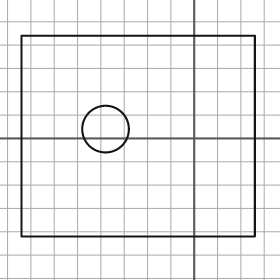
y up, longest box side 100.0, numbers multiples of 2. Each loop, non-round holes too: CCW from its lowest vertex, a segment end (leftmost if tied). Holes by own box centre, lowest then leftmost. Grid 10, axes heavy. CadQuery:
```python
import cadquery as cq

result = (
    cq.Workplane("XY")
    .moveTo(-74.0, -42.0)
    .lineTo(26.0, -42.0)
    .lineTo(26.0, 44.0)
    .lineTo(-74.0, 44.0)
    .close()
    .moveTo(-38.0, 4.0)
    .circle(10.0)
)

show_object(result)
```